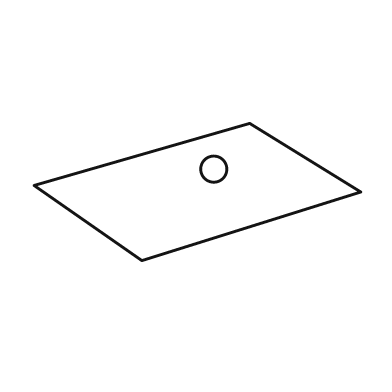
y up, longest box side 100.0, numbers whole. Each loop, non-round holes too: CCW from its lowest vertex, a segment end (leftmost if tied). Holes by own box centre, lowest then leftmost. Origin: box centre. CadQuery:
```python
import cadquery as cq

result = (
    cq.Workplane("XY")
    .moveTo(-17.0, -21.0)
    .lineTo(50.0, 0.0)
    .lineTo(16.0, 21.0)
    .lineTo(-50.0, 2.0)
    .close()
    .moveTo(5.0, 7.0)
    .circle(4.0)
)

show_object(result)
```